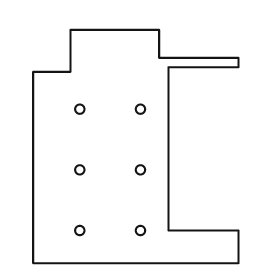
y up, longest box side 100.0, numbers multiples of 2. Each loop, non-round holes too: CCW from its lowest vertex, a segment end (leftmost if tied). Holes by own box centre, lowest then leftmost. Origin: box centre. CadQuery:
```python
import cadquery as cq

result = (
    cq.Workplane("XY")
    .moveTo(-44.0, -50.0)
    .lineTo(44.0, -50.0)
    .lineTo(44.0, -36.0)
    .lineTo(14.0, -36.0)
    .lineTo(14.0, 34.0)
    .lineTo(44.0, 34.0)
    .lineTo(44.0, 38.0)
    .lineTo(10.0, 38.0)
    .lineTo(10.0, 50.0)
    .lineTo(-28.0, 50.0)
    .lineTo(-28.0, 32.0)
    .lineTo(-44.0, 32.0)
    .close()
    .moveTo(-24.0, -36.0)
    .circle(2.0)
    .moveTo(2.0, -36.0)
    .circle(2.0)
    .moveTo(-24.0, -10.0)
    .circle(2.0)
    .moveTo(2.0, -10.0)
    .circle(2.0)
    .moveTo(-24.0, 16.0)
    .circle(2.0)
    .moveTo(2.0, 16.0)
    .circle(2.0)
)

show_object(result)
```